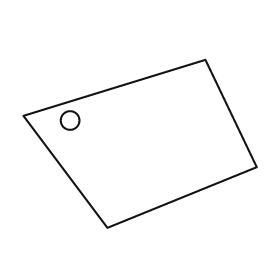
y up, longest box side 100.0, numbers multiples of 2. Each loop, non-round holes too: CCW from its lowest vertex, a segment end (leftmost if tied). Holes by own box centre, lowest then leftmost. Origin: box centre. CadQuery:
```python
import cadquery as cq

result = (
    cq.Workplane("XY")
    .moveTo(-14.0, -36.0)
    .lineTo(50.0, -10.0)
    .lineTo(28.0, 36.0)
    .lineTo(-50.0, 12.0)
    .close()
    .moveTo(-30.0, 10.0)
    .circle(4.0)
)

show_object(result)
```